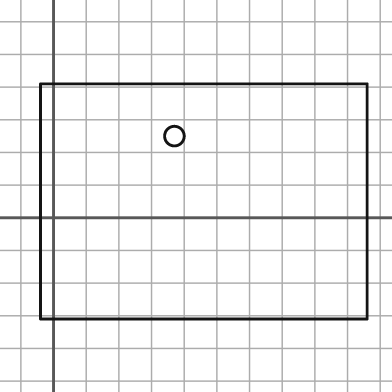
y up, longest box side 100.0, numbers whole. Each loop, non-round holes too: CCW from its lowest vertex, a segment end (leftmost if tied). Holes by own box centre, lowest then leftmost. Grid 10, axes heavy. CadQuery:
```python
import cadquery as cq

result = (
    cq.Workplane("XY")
    .moveTo(-4.0, -31.0)
    .lineTo(96.0, -31.0)
    .lineTo(96.0, 41.0)
    .lineTo(-4.0, 41.0)
    .close()
    .moveTo(37.0, 25.0)
    .circle(3.0)
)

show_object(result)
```